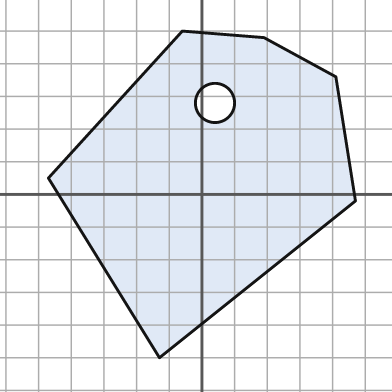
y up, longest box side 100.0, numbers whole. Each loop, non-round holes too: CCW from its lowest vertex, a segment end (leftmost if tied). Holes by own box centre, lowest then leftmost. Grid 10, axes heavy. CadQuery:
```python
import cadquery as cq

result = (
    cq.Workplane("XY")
    .moveTo(-13.0, -50.0)
    .lineTo(47.0, -2.0)
    .lineTo(41.0, 36.0)
    .lineTo(19.0, 48.0)
    .lineTo(-6.0, 50.0)
    .lineTo(-47.0, 5.0)
    .close()
    .moveTo(4.0, 28.0)
    .circle(6.0)
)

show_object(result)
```